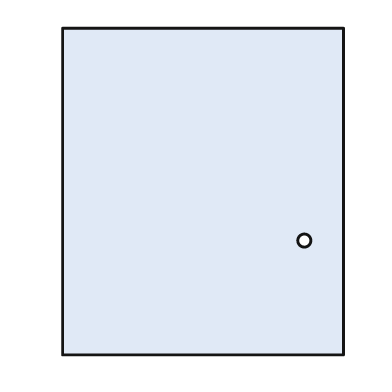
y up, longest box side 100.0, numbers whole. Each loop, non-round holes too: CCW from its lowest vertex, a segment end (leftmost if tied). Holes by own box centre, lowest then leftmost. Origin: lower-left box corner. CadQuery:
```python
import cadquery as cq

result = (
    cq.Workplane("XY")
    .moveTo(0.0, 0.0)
    .lineTo(86.0, 0.0)
    .lineTo(86.0, 100.0)
    .lineTo(0.0, 100.0)
    .close()
    .moveTo(74.0, 35.0)
    .circle(2.0)
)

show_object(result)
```